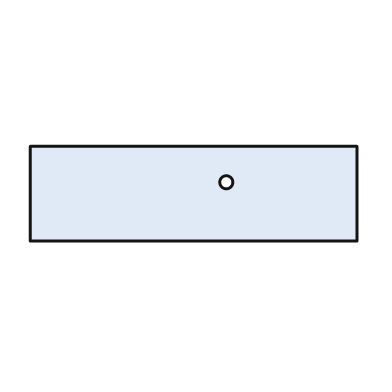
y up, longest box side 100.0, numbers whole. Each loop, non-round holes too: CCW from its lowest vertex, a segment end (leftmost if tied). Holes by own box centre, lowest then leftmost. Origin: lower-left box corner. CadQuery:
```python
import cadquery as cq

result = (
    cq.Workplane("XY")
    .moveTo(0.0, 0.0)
    .lineTo(100.0, 0.0)
    .lineTo(100.0, 29.0)
    .lineTo(0.0, 29.0)
    .close()
    .moveTo(60.0, 18.0)
    .circle(2.0)
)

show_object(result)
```